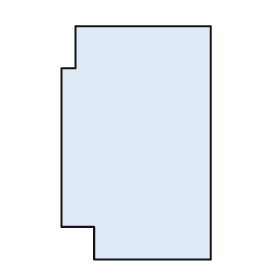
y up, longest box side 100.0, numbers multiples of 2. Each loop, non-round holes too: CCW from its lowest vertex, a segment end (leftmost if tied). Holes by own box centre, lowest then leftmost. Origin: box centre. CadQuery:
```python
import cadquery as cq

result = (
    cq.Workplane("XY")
    .moveTo(-18.0, -50.0)
    .lineTo(32.0, -50.0)
    .lineTo(32.0, 50.0)
    .lineTo(-26.0, 50.0)
    .lineTo(-26.0, 32.0)
    .lineTo(-32.0, 32.0)
    .lineTo(-32.0, -36.0)
    .lineTo(-18.0, -36.0)
    .close()
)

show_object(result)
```